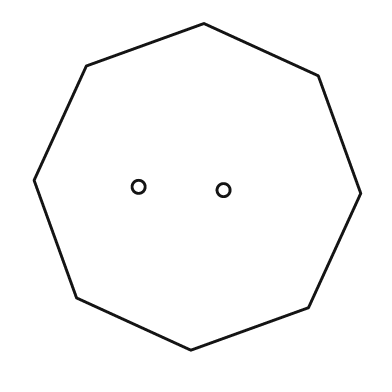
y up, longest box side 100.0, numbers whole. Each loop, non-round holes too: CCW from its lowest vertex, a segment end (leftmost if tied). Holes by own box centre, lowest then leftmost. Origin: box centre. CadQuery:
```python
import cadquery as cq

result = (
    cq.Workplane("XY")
    .moveTo(-2.0, -50.0)
    .lineTo(34.0, -37.0)
    .lineTo(50.0, -2.0)
    .lineTo(37.0, 34.0)
    .lineTo(2.0, 50.0)
    .lineTo(-34.0, 37.0)
    .lineTo(-50.0, 2.0)
    .lineTo(-37.0, -34.0)
    .close()
    .moveTo(8.0, -1.0)
    .circle(2.0)
    .moveTo(-18.0, 0.0)
    .circle(2.0)
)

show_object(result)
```